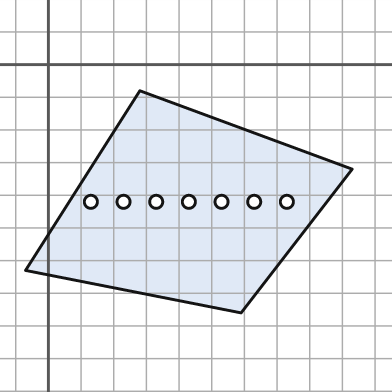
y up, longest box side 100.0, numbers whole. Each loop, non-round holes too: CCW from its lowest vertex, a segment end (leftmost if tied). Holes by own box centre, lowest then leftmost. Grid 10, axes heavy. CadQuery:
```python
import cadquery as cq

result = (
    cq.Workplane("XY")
    .moveTo(59.0, -76.0)
    .lineTo(93.0, -32.0)
    .lineTo(28.0, -8.0)
    .lineTo(-7.0, -63.0)
    .close()
    .moveTo(13.0, -42.0)
    .circle(2.0)
    .moveTo(23.0, -42.0)
    .circle(2.0)
    .moveTo(33.0, -42.0)
    .circle(2.0)
    .moveTo(43.0, -42.0)
    .circle(2.0)
    .moveTo(53.0, -42.0)
    .circle(2.0)
    .moveTo(63.0, -42.0)
    .circle(2.0)
    .moveTo(73.0, -42.0)
    .circle(2.0)
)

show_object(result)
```